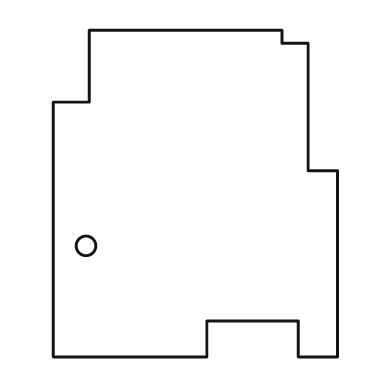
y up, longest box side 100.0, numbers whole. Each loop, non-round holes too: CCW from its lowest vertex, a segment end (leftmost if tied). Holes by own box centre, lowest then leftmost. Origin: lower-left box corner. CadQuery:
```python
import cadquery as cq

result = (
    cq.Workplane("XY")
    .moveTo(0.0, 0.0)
    .lineTo(47.0, 0.0)
    .lineTo(47.0, 11.0)
    .lineTo(75.0, 11.0)
    .lineTo(75.0, 0.0)
    .lineTo(87.0, 0.0)
    .lineTo(87.0, 57.0)
    .lineTo(78.0, 57.0)
    .lineTo(78.0, 96.0)
    .lineTo(70.0, 96.0)
    .lineTo(70.0, 100.0)
    .lineTo(11.0, 100.0)
    .lineTo(11.0, 78.0)
    .lineTo(0.0, 78.0)
    .close()
    .moveTo(10.0, 34.0)
    .circle(3.0)
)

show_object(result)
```